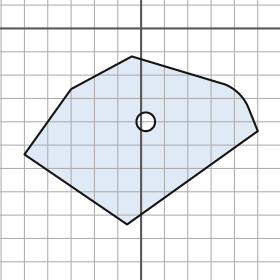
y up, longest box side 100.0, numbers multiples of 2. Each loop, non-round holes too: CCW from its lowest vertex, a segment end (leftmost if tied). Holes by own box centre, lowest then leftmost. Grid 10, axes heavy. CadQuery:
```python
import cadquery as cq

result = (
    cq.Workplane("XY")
    .moveTo(-6.0, -84.0)
    .lineTo(50.0, -44.0)
    .lineTo(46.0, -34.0)
    .threePointArc((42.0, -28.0), (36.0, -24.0))
    .lineTo(-4.0, -12.0)
    .lineTo(-30.0, -26.0)
    .lineTo(-50.0, -54.0)
    .close()
    .moveTo(2.0, -40.0)
    .circle(4.0)
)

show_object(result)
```